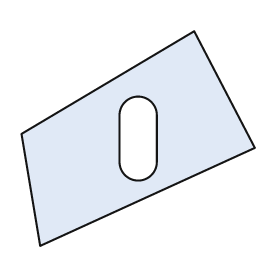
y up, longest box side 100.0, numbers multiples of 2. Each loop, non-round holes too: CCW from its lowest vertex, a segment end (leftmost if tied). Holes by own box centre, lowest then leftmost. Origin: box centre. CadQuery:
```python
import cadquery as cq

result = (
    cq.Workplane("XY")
    .moveTo(-42.0, -46.0)
    .lineTo(50.0, -4.0)
    .lineTo(24.0, 46.0)
    .lineTo(-50.0, 2.0)
    .close()
    .moveTo(-8.0, -10.0)
    .threePointArc((0.0, -18.0), (8.0, -10.0))
    .lineTo(8.0, 10.0)
    .threePointArc((0.0, 18.0), (-8.0, 10.0))
    .close()
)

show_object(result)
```